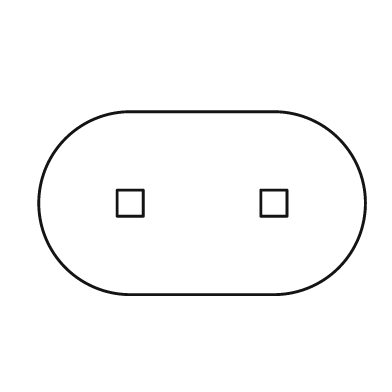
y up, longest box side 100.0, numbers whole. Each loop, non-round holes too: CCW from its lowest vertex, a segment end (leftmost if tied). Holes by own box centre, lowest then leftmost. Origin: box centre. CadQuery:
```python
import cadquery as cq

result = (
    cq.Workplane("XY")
    .moveTo(-22.0, -28.0)
    .lineTo(22.0, -28.0)
    .threePointArc((50.0, 0.0), (22.0, 28.0))
    .lineTo(-22.0, 28.0)
    .threePointArc((-50.0, 0.0), (-22.0, -28.0))
    .close()
    .moveTo(-26.0, -4.0)
    .lineTo(-18.0, -4.0)
    .lineTo(-18.0, 4.0)
    .lineTo(-26.0, 4.0)
    .close()
    .moveTo(18.0, -4.0)
    .lineTo(26.0, -4.0)
    .lineTo(26.0, 4.0)
    .lineTo(18.0, 4.0)
    .close()
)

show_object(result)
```